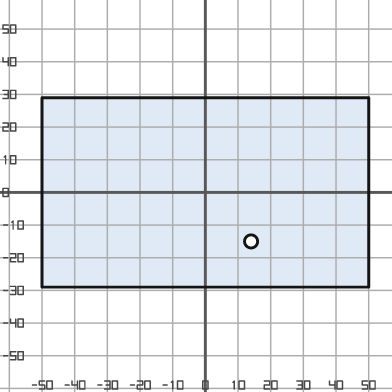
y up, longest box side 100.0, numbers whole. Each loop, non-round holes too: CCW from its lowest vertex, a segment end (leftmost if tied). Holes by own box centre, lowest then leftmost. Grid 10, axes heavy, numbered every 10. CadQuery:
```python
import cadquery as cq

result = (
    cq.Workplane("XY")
    .moveTo(-50.0, -29.0)
    .lineTo(50.0, -29.0)
    .lineTo(50.0, 29.0)
    .lineTo(-50.0, 29.0)
    .close()
    .moveTo(14.0, -15.0)
    .circle(2.0)
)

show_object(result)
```